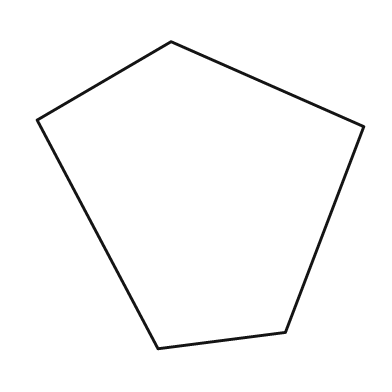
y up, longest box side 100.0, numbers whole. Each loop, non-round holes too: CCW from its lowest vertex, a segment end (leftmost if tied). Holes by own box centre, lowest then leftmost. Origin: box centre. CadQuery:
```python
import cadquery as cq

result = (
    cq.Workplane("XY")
    .moveTo(-13.0, -47.0)
    .lineTo(26.0, -42.0)
    .lineTo(50.0, 21.0)
    .lineTo(-9.0, 47.0)
    .lineTo(-50.0, 23.0)
    .close()
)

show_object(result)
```